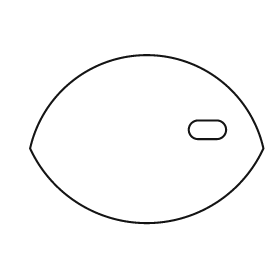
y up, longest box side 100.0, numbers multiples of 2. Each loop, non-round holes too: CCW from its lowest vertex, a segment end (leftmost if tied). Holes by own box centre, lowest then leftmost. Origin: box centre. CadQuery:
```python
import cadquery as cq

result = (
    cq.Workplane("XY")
    .moveTo(-50.0, -4.0)
    .threePointArc((0.0, -36.0), (50.0, -4.0))
    .threePointArc((0.0, 36.0), (-50.0, -4.0))
    .close()
    .moveTo(22.0, 0.0)
    .lineTo(30.0, 0.0)
    .threePointArc((34.0, 4.0), (30.0, 8.0))
    .lineTo(22.0, 8.0)
    .threePointArc((18.0, 4.0), (22.0, 0.0))
    .close()
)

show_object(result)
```